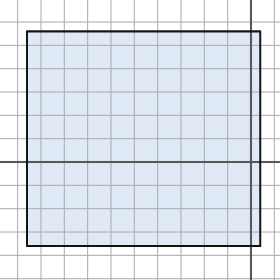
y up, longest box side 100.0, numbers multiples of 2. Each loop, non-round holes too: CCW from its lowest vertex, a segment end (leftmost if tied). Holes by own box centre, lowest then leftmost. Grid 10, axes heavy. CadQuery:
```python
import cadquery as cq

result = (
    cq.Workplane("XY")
    .moveTo(-96.0, -36.0)
    .lineTo(4.0, -36.0)
    .lineTo(4.0, 56.0)
    .lineTo(-96.0, 56.0)
    .close()
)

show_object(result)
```